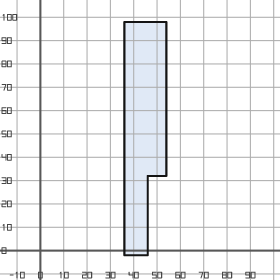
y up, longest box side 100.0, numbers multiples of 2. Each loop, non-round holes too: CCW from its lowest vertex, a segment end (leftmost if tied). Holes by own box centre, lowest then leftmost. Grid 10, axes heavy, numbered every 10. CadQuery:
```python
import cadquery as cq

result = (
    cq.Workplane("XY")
    .moveTo(36.0, -2.0)
    .lineTo(46.0, -2.0)
    .lineTo(46.0, 32.0)
    .lineTo(54.0, 32.0)
    .lineTo(54.0, 98.0)
    .lineTo(36.0, 98.0)
    .close()
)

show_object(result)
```